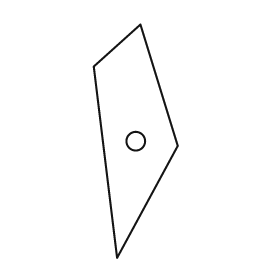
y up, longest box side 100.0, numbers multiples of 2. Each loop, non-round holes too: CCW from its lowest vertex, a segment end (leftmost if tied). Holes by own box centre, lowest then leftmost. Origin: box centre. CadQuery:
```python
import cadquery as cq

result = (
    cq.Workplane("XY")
    .moveTo(-8.0, -50.0)
    .lineTo(18.0, -2.0)
    .lineTo(2.0, 50.0)
    .lineTo(-18.0, 32.0)
    .close()
    .moveTo(0.0, 0.0)
    .circle(4.0)
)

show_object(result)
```